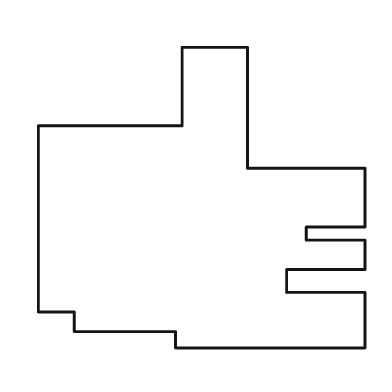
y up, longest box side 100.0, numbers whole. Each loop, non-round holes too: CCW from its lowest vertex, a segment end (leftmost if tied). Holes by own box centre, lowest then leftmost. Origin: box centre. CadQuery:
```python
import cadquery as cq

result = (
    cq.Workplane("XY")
    .moveTo(-8.0, -46.0)
    .lineTo(50.0, -46.0)
    .lineTo(50.0, -29.0)
    .lineTo(26.0, -29.0)
    .lineTo(26.0, -22.0)
    .lineTo(50.0, -22.0)
    .lineTo(50.0, -13.0)
    .lineTo(32.0, -13.0)
    .lineTo(32.0, -9.0)
    .lineTo(50.0, -9.0)
    .lineTo(50.0, 9.0)
    .lineTo(14.0, 9.0)
    .lineTo(14.0, 46.0)
    .lineTo(-6.0, 46.0)
    .lineTo(-6.0, 22.0)
    .lineTo(-50.0, 22.0)
    .lineTo(-50.0, -35.0)
    .lineTo(-39.0, -35.0)
    .lineTo(-39.0, -41.0)
    .lineTo(-8.0, -41.0)
    .close()
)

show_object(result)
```